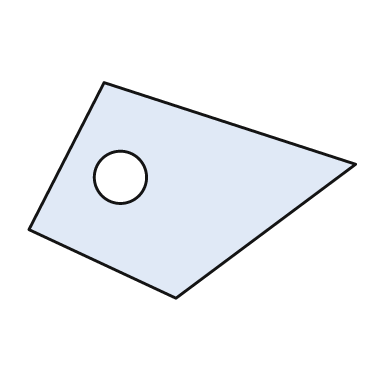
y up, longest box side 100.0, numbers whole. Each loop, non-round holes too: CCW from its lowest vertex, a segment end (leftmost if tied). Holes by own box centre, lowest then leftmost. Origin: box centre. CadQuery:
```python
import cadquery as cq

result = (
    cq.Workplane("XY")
    .moveTo(-5.0, -33.0)
    .lineTo(50.0, 8.0)
    .lineTo(-27.0, 33.0)
    .lineTo(-50.0, -12.0)
    .close()
    .moveTo(-22.0, 4.0)
    .circle(8.0)
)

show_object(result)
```